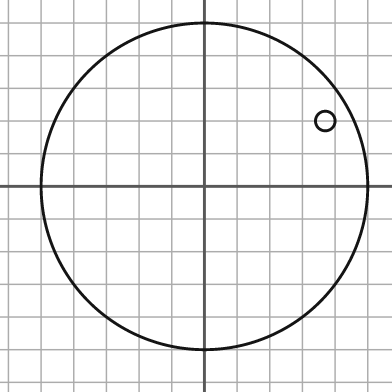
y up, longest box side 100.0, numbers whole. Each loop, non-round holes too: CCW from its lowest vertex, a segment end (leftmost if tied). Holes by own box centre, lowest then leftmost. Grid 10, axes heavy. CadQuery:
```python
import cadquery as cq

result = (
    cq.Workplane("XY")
    .moveTo(0.0, 0.0)
    .circle(50.0)
    .moveTo(37.0, 20.0)
    .circle(3.0)
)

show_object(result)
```